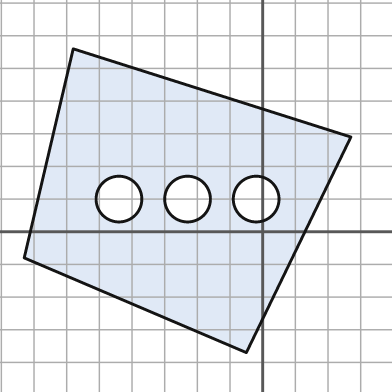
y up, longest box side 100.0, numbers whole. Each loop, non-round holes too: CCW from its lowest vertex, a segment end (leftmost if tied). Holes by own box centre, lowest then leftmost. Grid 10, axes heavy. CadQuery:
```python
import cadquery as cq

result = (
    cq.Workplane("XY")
    .moveTo(-5.0, -37.0)
    .lineTo(27.0, 29.0)
    .lineTo(-58.0, 56.0)
    .lineTo(-73.0, -8.0)
    .close()
    .moveTo(-44.0, 10.0)
    .circle(7.0)
    .moveTo(-23.0, 10.0)
    .circle(7.0)
    .moveTo(-2.0, 10.0)
    .circle(7.0)
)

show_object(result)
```